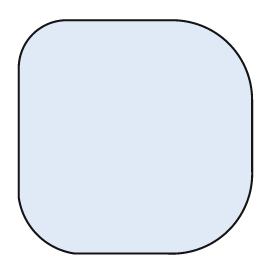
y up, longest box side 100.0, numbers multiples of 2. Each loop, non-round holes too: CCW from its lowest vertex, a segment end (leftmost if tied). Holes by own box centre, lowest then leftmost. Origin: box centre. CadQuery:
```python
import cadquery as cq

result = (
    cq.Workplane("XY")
    .moveTo(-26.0, -50.0)
    .lineTo(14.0, -50.0)
    .threePointArc((40.0, -40.0), (50.0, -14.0))
    .lineTo(50.0, 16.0)
    .threePointArc((40.0, 40.0), (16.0, 50.0))
    .lineTo(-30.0, 50.0)
    .threePointArc((-44.0, 44.0), (-50.0, 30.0))
    .lineTo(-50.0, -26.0)
    .threePointArc((-42.0, -42.0), (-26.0, -50.0))
    .close()
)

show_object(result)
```